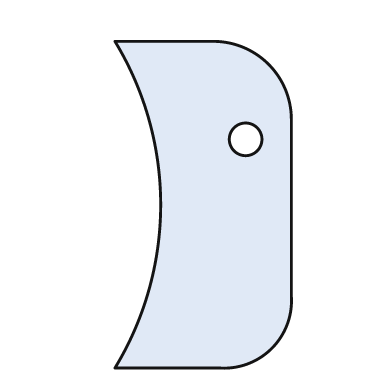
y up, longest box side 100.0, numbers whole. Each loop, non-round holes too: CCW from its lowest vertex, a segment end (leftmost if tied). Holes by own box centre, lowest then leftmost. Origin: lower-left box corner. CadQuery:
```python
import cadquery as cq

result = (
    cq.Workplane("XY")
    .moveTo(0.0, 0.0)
    .lineTo(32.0, 0.0)
    .threePointArc((48.0, 6.0), (54.0, 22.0))
    .lineTo(54.0, 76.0)
    .threePointArc((47.0, 93.0), (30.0, 100.0))
    .lineTo(0.0, 100.0)
    .threePointArc((14.0, 50.0), (0.0, 0.0))
    .close()
    .moveTo(40.0, 70.0)
    .circle(5.0)
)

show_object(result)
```